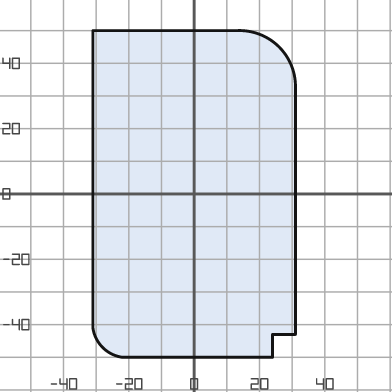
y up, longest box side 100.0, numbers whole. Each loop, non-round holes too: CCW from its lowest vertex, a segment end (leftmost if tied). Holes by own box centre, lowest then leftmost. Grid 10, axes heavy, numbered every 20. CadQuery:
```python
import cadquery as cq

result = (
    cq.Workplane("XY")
    .moveTo(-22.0, -50.0)
    .lineTo(24.0, -50.0)
    .lineTo(24.0, -43.0)
    .lineTo(31.0, -43.0)
    .lineTo(31.0, 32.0)
    .threePointArc((26.0, 45.0), (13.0, 50.0))
    .lineTo(-31.0, 50.0)
    .lineTo(-31.0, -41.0)
    .threePointArc((-28.0, -47.0), (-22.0, -50.0))
    .close()
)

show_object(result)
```